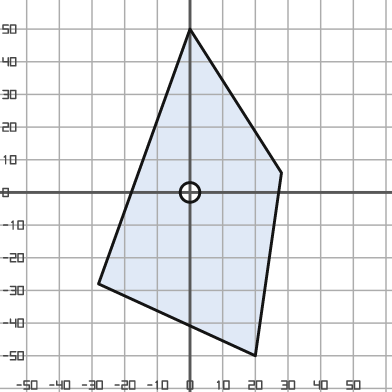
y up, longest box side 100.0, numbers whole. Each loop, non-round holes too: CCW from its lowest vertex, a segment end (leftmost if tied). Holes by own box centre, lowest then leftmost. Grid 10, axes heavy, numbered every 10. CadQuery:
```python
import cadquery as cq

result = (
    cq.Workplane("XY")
    .moveTo(20.0, -50.0)
    .lineTo(28.0, 6.0)
    .lineTo(0.0, 50.0)
    .lineTo(-28.0, -28.0)
    .close()
    .moveTo(0.0, 0.0)
    .circle(3.0)
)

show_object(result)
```